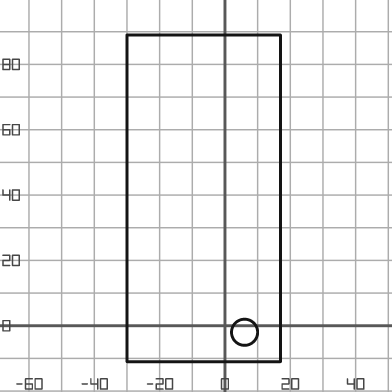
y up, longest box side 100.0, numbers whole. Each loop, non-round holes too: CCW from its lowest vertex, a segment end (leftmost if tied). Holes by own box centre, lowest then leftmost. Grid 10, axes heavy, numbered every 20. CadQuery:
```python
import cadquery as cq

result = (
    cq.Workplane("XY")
    .moveTo(-30.0, -11.0)
    .lineTo(17.0, -11.0)
    .lineTo(17.0, 89.0)
    .lineTo(-30.0, 89.0)
    .close()
    .moveTo(6.0, -2.0)
    .circle(4.0)
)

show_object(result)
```